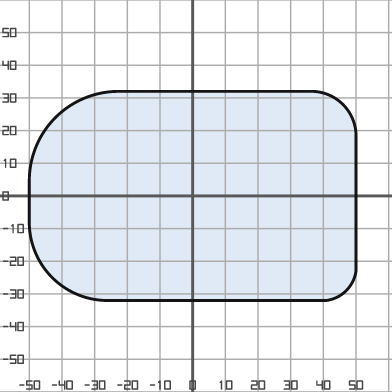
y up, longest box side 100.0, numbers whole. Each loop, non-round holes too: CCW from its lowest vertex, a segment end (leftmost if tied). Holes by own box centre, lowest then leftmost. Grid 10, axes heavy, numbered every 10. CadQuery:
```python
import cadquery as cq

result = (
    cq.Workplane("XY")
    .moveTo(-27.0, -32.0)
    .lineTo(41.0, -32.0)
    .threePointArc((47.0, -29.0), (50.0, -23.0))
    .lineTo(50.0, 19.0)
    .threePointArc((46.0, 28.0), (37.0, 32.0))
    .lineTo(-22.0, 32.0)
    .threePointArc((-42.0, 24.0), (-50.0, 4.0))
    .lineTo(-50.0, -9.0)
    .threePointArc((-43.0, -25.0), (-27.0, -32.0))
    .close()
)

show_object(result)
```